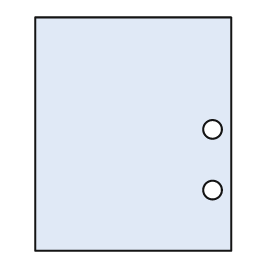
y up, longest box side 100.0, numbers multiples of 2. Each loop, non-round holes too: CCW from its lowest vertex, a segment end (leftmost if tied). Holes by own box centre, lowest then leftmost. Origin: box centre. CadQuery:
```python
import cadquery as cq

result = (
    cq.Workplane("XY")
    .moveTo(-42.0, -50.0)
    .lineTo(42.0, -50.0)
    .lineTo(42.0, 50.0)
    .lineTo(-42.0, 50.0)
    .close()
    .moveTo(34.0, -24.0)
    .circle(4.0)
    .moveTo(34.0, 2.0)
    .circle(4.0)
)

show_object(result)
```